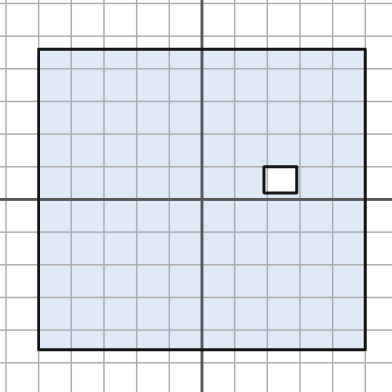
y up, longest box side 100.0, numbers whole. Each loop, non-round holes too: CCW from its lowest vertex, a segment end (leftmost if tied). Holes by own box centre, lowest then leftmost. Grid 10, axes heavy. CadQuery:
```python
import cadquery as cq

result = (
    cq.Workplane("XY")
    .moveTo(-50.0, -46.0)
    .lineTo(50.0, -46.0)
    .lineTo(50.0, 46.0)
    .lineTo(-50.0, 46.0)
    .close()
    .moveTo(19.0, 2.0)
    .lineTo(29.0, 2.0)
    .lineTo(29.0, 10.0)
    .lineTo(19.0, 10.0)
    .close()
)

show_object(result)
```